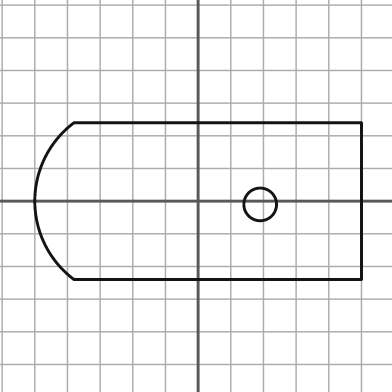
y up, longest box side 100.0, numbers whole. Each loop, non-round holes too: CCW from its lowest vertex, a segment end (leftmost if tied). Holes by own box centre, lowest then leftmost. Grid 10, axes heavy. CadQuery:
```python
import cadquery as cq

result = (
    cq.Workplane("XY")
    .moveTo(-38.0, -24.0)
    .lineTo(50.0, -24.0)
    .lineTo(50.0, 24.0)
    .lineTo(-38.0, 24.0)
    .threePointArc((-50.0, 0.0), (-38.0, -24.0))
    .close()
    .moveTo(19.0, -1.0)
    .circle(5.0)
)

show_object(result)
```